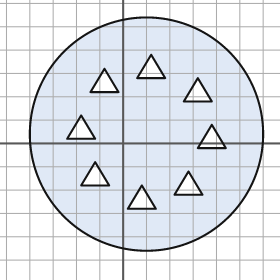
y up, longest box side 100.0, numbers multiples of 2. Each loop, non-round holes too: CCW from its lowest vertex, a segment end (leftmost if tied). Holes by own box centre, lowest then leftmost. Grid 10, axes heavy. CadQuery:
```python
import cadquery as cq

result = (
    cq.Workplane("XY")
    .moveTo(10.0, 4.0)
    .circle(50.0)
    .moveTo(2.0, -28.0)
    .lineTo(14.0, -28.0)
    .lineTo(8.0, -18.0)
    .close()
    .moveTo(22.0, -22.0)
    .lineTo(34.0, -22.0)
    .lineTo(28.0, -12.0)
    .close()
    .moveTo(-18.0, -18.0)
    .lineTo(-6.0, -18.0)
    .lineTo(-12.0, -8.0)
    .close()
    .moveTo(32.0, -2.0)
    .lineTo(44.0, -2.0)
    .lineTo(38.0, 8.0)
    .close()
    .moveTo(-24.0, 2.0)
    .lineTo(-12.0, 2.0)
    .lineTo(-18.0, 12.0)
    .close()
    .moveTo(26.0, 18.0)
    .lineTo(38.0, 18.0)
    .lineTo(32.0, 28.0)
    .close()
    .moveTo(-14.0, 22.0)
    .lineTo(-2.0, 22.0)
    .lineTo(-8.0, 32.0)
    .close()
    .moveTo(6.0, 28.0)
    .lineTo(18.0, 28.0)
    .lineTo(12.0, 38.0)
    .close()
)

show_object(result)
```